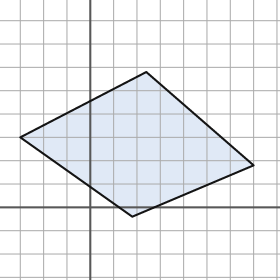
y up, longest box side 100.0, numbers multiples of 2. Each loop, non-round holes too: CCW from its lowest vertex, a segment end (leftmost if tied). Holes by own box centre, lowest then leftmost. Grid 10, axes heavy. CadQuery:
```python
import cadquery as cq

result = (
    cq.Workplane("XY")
    .moveTo(18.0, -4.0)
    .lineTo(70.0, 18.0)
    .lineTo(24.0, 58.0)
    .lineTo(-30.0, 30.0)
    .close()
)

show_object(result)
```